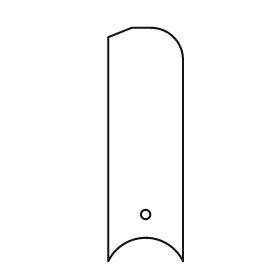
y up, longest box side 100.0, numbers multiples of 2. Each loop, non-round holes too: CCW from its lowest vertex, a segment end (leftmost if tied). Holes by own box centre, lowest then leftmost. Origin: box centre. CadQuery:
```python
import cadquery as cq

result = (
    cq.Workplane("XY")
    .moveTo(-16.0, -50.0)
    .threePointArc((0.0, -40.0), (16.0, -50.0))
    .lineTo(16.0, 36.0)
    .threePointArc((12.0, 46.0), (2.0, 50.0))
    .lineTo(-6.0, 50.0)
    .lineTo(-16.0, 46.0)
    .close()
    .moveTo(0.0, -30.0)
    .circle(2.0)
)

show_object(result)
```